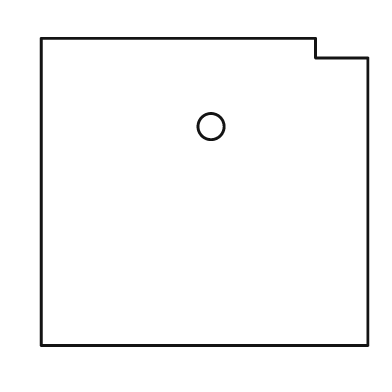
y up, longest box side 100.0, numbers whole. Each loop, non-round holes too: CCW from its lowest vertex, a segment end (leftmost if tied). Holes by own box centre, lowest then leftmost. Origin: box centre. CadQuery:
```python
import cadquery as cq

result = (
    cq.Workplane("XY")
    .moveTo(-50.0, -47.0)
    .lineTo(50.0, -47.0)
    .lineTo(50.0, 41.0)
    .lineTo(34.0, 41.0)
    .lineTo(34.0, 47.0)
    .lineTo(-50.0, 47.0)
    .close()
    .moveTo(2.0, 20.0)
    .circle(4.0)
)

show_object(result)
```